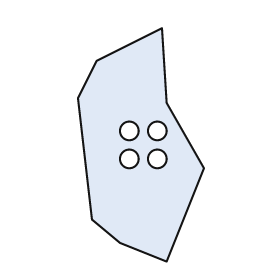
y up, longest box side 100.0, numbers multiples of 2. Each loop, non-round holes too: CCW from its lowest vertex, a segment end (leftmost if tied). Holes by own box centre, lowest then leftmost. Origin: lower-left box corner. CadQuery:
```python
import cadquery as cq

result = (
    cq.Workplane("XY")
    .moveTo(38.0, 0.0)
    .lineTo(54.0, 40.0)
    .lineTo(38.0, 68.0)
    .lineTo(36.0, 100.0)
    .lineTo(8.0, 86.0)
    .lineTo(0.0, 70.0)
    .lineTo(6.0, 18.0)
    .lineTo(18.0, 8.0)
    .close()
    .moveTo(22.0, 44.0)
    .circle(4.0)
    .moveTo(34.0, 44.0)
    .circle(4.0)
    .moveTo(22.0, 56.0)
    .circle(4.0)
    .moveTo(34.0, 56.0)
    .circle(4.0)
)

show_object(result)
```